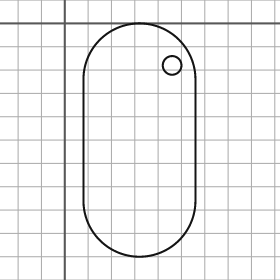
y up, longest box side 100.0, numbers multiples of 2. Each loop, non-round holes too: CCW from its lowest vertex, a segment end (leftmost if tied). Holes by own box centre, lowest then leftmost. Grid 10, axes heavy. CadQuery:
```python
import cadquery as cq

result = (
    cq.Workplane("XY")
    .moveTo(8.0, -76.0)
    .threePointArc((32.0, -100.0), (56.0, -76.0))
    .lineTo(56.0, -24.0)
    .threePointArc((32.0, 0.0), (8.0, -24.0))
    .close()
    .moveTo(46.0, -18.0)
    .circle(4.0)
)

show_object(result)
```